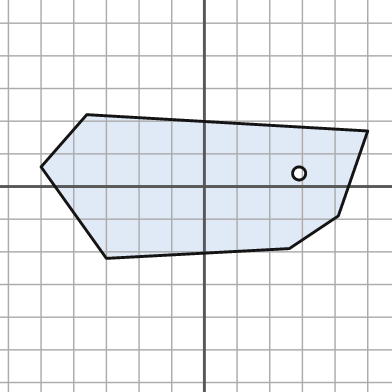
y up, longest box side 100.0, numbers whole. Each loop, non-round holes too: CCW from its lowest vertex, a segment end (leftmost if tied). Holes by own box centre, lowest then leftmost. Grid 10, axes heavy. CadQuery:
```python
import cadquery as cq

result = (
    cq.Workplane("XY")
    .moveTo(-30.0, -22.0)
    .lineTo(26.0, -19.0)
    .lineTo(41.0, -9.0)
    .lineTo(50.0, 17.0)
    .lineTo(-36.0, 22.0)
    .lineTo(-50.0, 6.0)
    .close()
    .moveTo(29.0, 4.0)
    .circle(2.0)
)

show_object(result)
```